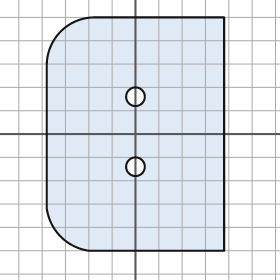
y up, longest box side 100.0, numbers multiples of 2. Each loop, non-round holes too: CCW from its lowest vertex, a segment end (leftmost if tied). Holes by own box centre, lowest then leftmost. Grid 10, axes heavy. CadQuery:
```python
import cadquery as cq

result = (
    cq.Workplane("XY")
    .moveTo(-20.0, -50.0)
    .lineTo(38.0, -50.0)
    .lineTo(38.0, 50.0)
    .lineTo(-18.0, 50.0)
    .threePointArc((-32.0, 44.0), (-38.0, 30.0))
    .lineTo(-38.0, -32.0)
    .threePointArc((-32.0, -44.0), (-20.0, -50.0))
    .close()
    .moveTo(0.0, -14.0)
    .circle(4.0)
    .moveTo(0.0, 16.0)
    .circle(4.0)
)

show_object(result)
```